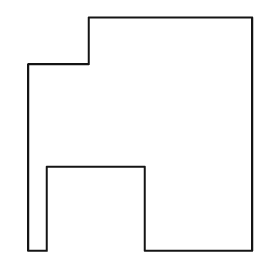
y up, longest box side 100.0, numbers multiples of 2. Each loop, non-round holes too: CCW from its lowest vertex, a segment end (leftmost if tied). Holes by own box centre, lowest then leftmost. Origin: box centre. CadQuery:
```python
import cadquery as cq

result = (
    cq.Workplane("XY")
    .moveTo(-48.0, -50.0)
    .lineTo(-40.0, -50.0)
    .lineTo(-40.0, -14.0)
    .lineTo(2.0, -14.0)
    .lineTo(2.0, -50.0)
    .lineTo(48.0, -50.0)
    .lineTo(48.0, 50.0)
    .lineTo(-22.0, 50.0)
    .lineTo(-22.0, 30.0)
    .lineTo(-48.0, 30.0)
    .close()
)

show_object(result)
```